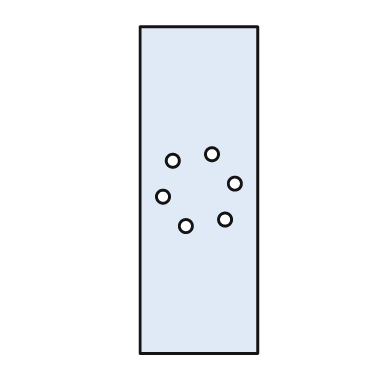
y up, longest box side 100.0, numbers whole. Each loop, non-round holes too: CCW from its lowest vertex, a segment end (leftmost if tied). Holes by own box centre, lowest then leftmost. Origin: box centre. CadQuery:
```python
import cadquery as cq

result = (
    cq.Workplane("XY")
    .moveTo(-18.0, -50.0)
    .lineTo(18.0, -50.0)
    .lineTo(18.0, 50.0)
    .lineTo(-18.0, 50.0)
    .close()
    .moveTo(-4.0, -11.0)
    .circle(2.0)
    .moveTo(8.0, -9.0)
    .circle(2.0)
    .moveTo(-11.0, -2.0)
    .circle(2.0)
    .moveTo(11.0, 2.0)
    .circle(2.0)
    .moveTo(-8.0, 9.0)
    .circle(2.0)
    .moveTo(4.0, 11.0)
    .circle(2.0)
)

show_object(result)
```